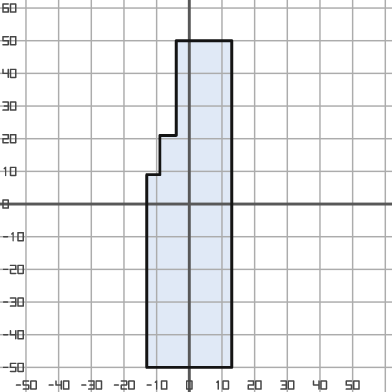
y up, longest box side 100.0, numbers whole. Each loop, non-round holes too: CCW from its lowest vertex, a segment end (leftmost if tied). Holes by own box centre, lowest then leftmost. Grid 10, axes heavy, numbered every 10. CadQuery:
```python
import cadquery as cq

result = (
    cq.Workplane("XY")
    .moveTo(-13.0, -50.0)
    .lineTo(13.0, -50.0)
    .lineTo(13.0, 50.0)
    .lineTo(-4.0, 50.0)
    .lineTo(-4.0, 21.0)
    .lineTo(-9.0, 21.0)
    .lineTo(-9.0, 9.0)
    .lineTo(-13.0, 9.0)
    .close()
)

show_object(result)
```